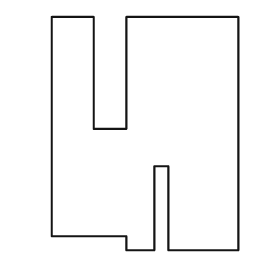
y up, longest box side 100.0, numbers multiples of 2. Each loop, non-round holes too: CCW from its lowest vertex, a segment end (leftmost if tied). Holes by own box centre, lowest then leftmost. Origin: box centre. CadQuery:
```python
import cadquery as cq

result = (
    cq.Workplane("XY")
    .moveTo(-8.0, -50.0)
    .lineTo(4.0, -50.0)
    .lineTo(4.0, -14.0)
    .lineTo(10.0, -14.0)
    .lineTo(10.0, -50.0)
    .lineTo(40.0, -50.0)
    .lineTo(40.0, 50.0)
    .lineTo(-8.0, 50.0)
    .lineTo(-8.0, 2.0)
    .lineTo(-22.0, 2.0)
    .lineTo(-22.0, 50.0)
    .lineTo(-40.0, 50.0)
    .lineTo(-40.0, -44.0)
    .lineTo(-8.0, -44.0)
    .close()
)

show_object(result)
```